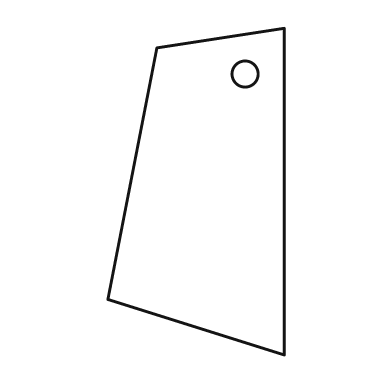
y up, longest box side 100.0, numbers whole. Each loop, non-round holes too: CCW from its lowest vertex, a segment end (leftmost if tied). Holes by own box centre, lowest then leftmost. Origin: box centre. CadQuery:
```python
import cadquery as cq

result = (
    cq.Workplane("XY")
    .moveTo(27.0, -50.0)
    .lineTo(27.0, 50.0)
    .lineTo(-12.0, 44.0)
    .lineTo(-27.0, -33.0)
    .close()
    .moveTo(15.0, 36.0)
    .circle(4.0)
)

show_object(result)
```